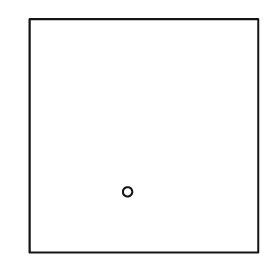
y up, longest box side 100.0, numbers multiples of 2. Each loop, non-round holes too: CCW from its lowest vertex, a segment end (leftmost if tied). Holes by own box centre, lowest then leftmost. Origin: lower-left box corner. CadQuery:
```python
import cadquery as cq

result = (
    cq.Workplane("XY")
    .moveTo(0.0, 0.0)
    .lineTo(98.0, 0.0)
    .lineTo(98.0, 100.0)
    .lineTo(0.0, 100.0)
    .close()
    .moveTo(42.0, 26.0)
    .circle(2.0)
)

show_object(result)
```